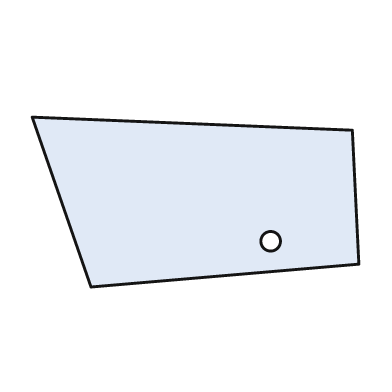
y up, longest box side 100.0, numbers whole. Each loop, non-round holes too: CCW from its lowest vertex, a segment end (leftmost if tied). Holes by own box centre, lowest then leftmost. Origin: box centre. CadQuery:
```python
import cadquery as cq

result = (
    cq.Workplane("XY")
    .moveTo(-32.0, -26.0)
    .lineTo(50.0, -19.0)
    .lineTo(48.0, 22.0)
    .lineTo(-50.0, 26.0)
    .close()
    .moveTo(23.0, -12.0)
    .circle(3.0)
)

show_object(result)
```